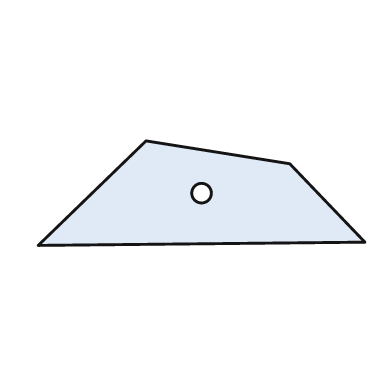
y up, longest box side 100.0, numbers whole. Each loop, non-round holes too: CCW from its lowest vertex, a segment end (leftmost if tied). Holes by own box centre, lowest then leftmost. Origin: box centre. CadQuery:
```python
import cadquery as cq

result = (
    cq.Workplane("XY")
    .moveTo(-50.0, -16.0)
    .lineTo(50.0, -15.0)
    .lineTo(27.0, 9.0)
    .lineTo(-17.0, 16.0)
    .close()
    .moveTo(0.0, 0.0)
    .circle(3.0)
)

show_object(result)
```